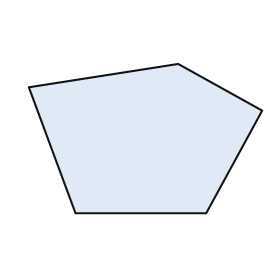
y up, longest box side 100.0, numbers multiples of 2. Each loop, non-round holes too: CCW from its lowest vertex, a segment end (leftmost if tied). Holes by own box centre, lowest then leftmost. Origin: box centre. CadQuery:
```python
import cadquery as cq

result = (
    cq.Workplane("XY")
    .moveTo(-30.0, -32.0)
    .lineTo(26.0, -32.0)
    .lineTo(50.0, 12.0)
    .lineTo(14.0, 32.0)
    .lineTo(-50.0, 22.0)
    .close()
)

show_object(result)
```